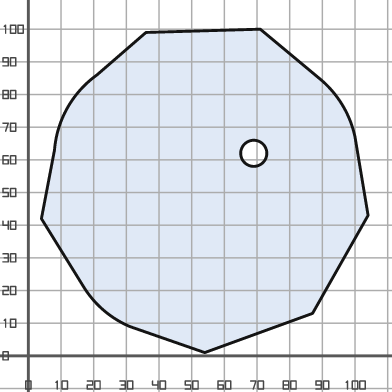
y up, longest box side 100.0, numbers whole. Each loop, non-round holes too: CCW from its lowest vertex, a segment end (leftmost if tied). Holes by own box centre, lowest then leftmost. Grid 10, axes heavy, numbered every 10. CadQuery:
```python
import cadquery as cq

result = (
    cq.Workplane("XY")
    .moveTo(54.0, 1.0)
    .lineTo(87.0, 13.0)
    .lineTo(104.0, 43.0)
    .lineTo(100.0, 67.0)
    .threePointArc((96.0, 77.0), (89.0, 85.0))
    .lineTo(71.0, 100.0)
    .lineTo(36.0, 99.0)
    .lineTo(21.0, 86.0)
    .threePointArc((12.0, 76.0), (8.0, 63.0))
    .lineTo(4.0, 42.0)
    .lineTo(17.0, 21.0)
    .threePointArc((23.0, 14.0), (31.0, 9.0))
    .close()
    .moveTo(69.0, 62.0)
    .circle(4.0)
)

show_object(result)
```